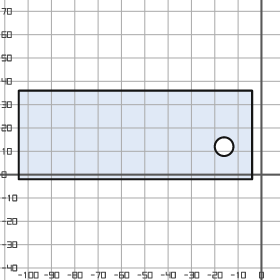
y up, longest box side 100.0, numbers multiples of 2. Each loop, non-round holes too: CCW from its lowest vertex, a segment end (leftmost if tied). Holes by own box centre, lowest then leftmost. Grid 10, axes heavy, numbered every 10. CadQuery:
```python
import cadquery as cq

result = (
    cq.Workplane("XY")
    .moveTo(-104.0, -2.0)
    .lineTo(-4.0, -2.0)
    .lineTo(-4.0, 36.0)
    .lineTo(-104.0, 36.0)
    .close()
    .moveTo(-16.0, 12.0)
    .circle(4.0)
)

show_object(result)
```